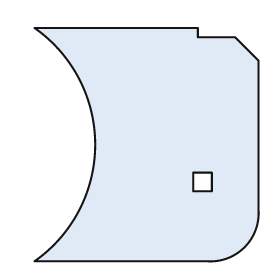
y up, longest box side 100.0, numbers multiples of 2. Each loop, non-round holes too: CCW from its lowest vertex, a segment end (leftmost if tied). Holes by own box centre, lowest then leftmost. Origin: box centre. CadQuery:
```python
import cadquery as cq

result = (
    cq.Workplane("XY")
    .moveTo(-48.0, -50.0)
    .lineTo(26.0, -50.0)
    .threePointArc((42.0, -44.0), (48.0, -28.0))
    .lineTo(48.0, 36.0)
    .lineTo(38.0, 46.0)
    .lineTo(22.0, 46.0)
    .lineTo(22.0, 50.0)
    .lineTo(-48.0, 50.0)
    .threePointArc((-22.0, 0.0), (-48.0, -50.0))
    .close()
    .moveTo(20.0, -20.0)
    .lineTo(28.0, -20.0)
    .lineTo(28.0, -12.0)
    .lineTo(20.0, -12.0)
    .close()
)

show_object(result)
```